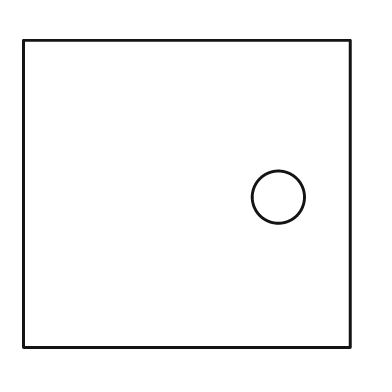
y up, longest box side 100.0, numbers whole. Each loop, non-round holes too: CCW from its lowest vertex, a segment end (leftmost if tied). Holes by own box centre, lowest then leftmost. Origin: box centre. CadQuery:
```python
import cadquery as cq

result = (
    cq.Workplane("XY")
    .moveTo(-50.0, -47.0)
    .lineTo(50.0, -47.0)
    .lineTo(50.0, 47.0)
    .lineTo(-50.0, 47.0)
    .close()
    .moveTo(28.0, -1.0)
    .circle(8.0)
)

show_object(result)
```